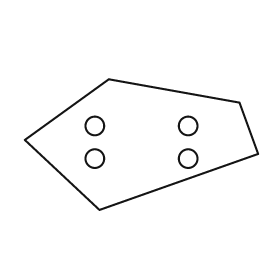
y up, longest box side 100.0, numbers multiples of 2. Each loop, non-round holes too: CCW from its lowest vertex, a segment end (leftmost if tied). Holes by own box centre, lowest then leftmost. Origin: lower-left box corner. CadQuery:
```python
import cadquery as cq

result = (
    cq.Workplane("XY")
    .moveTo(32.0, 0.0)
    .lineTo(100.0, 24.0)
    .lineTo(92.0, 46.0)
    .lineTo(36.0, 56.0)
    .lineTo(0.0, 30.0)
    .close()
    .moveTo(30.0, 22.0)
    .circle(4.0)
    .moveTo(70.0, 22.0)
    .circle(4.0)
    .moveTo(30.0, 36.0)
    .circle(4.0)
    .moveTo(70.0, 36.0)
    .circle(4.0)
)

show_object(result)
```